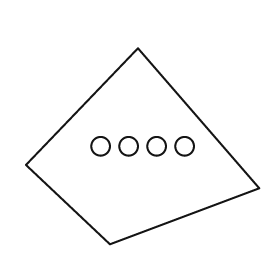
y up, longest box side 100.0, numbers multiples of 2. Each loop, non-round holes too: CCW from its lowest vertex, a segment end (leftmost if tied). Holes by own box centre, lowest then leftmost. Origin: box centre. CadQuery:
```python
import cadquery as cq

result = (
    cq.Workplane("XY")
    .moveTo(-14.0, -42.0)
    .lineTo(50.0, -18.0)
    .lineTo(-2.0, 42.0)
    .lineTo(-50.0, -8.0)
    .close()
    .moveTo(-18.0, 0.0)
    .circle(4.0)
    .moveTo(-6.0, 0.0)
    .circle(4.0)
    .moveTo(6.0, 0.0)
    .circle(4.0)
    .moveTo(18.0, 0.0)
    .circle(4.0)
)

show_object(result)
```